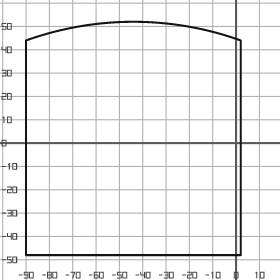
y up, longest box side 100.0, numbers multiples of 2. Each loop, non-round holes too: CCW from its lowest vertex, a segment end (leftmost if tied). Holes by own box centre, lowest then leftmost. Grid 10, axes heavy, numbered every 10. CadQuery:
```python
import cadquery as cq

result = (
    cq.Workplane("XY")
    .moveTo(-90.0, -48.0)
    .lineTo(2.0, -48.0)
    .lineTo(2.0, 44.0)
    .threePointArc((-44.0, 52.0), (-90.0, 44.0))
    .close()
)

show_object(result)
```